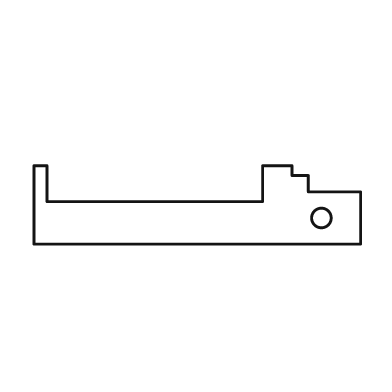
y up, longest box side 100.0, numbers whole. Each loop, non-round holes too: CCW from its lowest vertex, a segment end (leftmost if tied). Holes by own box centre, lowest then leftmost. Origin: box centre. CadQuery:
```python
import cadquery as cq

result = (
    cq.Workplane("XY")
    .moveTo(-50.0, -12.0)
    .lineTo(50.0, -12.0)
    .lineTo(50.0, 4.0)
    .lineTo(34.0, 4.0)
    .lineTo(34.0, 9.0)
    .lineTo(29.0, 9.0)
    .lineTo(29.0, 12.0)
    .lineTo(20.0, 12.0)
    .lineTo(20.0, 1.0)
    .lineTo(-46.0, 1.0)
    .lineTo(-46.0, 12.0)
    .lineTo(-50.0, 12.0)
    .close()
    .moveTo(38.0, -4.0)
    .circle(3.0)
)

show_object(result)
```